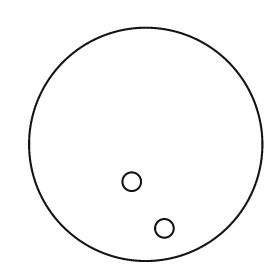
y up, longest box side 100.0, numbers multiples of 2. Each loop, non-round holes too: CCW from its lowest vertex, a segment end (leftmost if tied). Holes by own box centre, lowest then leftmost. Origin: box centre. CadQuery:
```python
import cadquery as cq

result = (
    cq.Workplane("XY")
    .moveTo(0.0, 0.0)
    .circle(50.0)
    .moveTo(8.0, -36.0)
    .circle(4.0)
    .moveTo(-6.0, -16.0)
    .circle(4.0)
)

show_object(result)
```